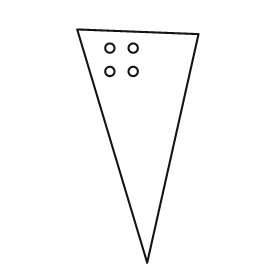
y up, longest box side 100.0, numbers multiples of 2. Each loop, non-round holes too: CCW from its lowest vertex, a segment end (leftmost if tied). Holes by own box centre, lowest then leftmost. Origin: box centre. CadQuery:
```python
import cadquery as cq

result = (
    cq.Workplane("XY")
    .moveTo(4.0, -50.0)
    .lineTo(26.0, 48.0)
    .lineTo(-26.0, 50.0)
    .close()
    .moveTo(-12.0, 32.0)
    .circle(2.0)
    .moveTo(-2.0, 32.0)
    .circle(2.0)
    .moveTo(-12.0, 42.0)
    .circle(2.0)
    .moveTo(-2.0, 42.0)
    .circle(2.0)
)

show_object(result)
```